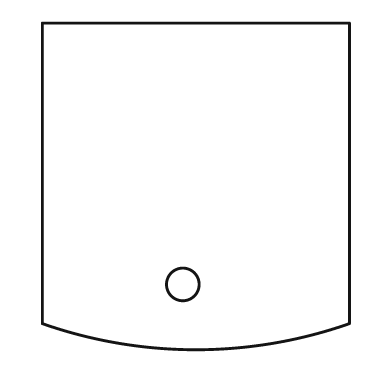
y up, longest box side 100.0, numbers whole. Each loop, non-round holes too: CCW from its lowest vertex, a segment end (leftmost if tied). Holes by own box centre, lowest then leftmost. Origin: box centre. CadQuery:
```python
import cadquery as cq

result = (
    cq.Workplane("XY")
    .moveTo(-47.0, -42.0)
    .threePointArc((0.0, -50.0), (47.0, -42.0))
    .lineTo(47.0, 50.0)
    .lineTo(-47.0, 50.0)
    .close()
    .moveTo(-4.0, -30.0)
    .circle(5.0)
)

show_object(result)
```